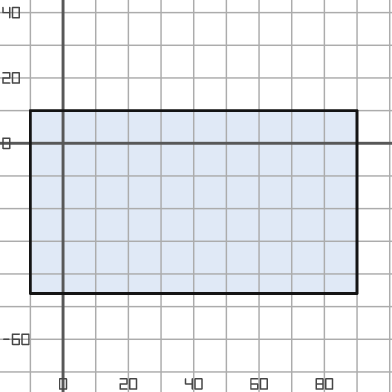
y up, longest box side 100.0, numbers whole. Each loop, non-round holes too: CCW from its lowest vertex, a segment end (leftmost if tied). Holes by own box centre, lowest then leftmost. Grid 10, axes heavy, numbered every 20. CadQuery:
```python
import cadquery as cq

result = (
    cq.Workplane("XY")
    .moveTo(-10.0, -46.0)
    .lineTo(90.0, -46.0)
    .lineTo(90.0, 10.0)
    .lineTo(-10.0, 10.0)
    .close()
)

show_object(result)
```